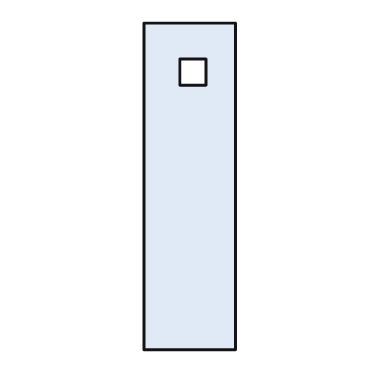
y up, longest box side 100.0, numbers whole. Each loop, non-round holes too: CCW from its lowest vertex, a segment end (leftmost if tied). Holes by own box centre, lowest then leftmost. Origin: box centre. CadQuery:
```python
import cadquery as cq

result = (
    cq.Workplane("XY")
    .moveTo(-14.0, -50.0)
    .lineTo(14.0, -50.0)
    .lineTo(14.0, 50.0)
    .lineTo(-14.0, 50.0)
    .close()
    .moveTo(-3.0, 31.0)
    .lineTo(5.0, 31.0)
    .lineTo(5.0, 39.0)
    .lineTo(-3.0, 39.0)
    .close()
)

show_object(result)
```